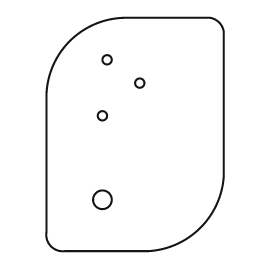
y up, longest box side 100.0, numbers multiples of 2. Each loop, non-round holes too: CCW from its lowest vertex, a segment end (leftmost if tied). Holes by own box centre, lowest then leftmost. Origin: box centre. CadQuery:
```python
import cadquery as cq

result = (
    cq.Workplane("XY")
    .moveTo(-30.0, -50.0)
    .lineTo(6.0, -50.0)
    .threePointArc((28.0, -40.0), (38.0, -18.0))
    .lineTo(38.0, 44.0)
    .threePointArc((36.0, 48.0), (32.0, 50.0))
    .lineTo(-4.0, 50.0)
    .threePointArc((-28.0, 40.0), (-38.0, 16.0))
    .lineTo(-38.0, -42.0)
    .threePointArc((-36.0, -48.0), (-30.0, -50.0))
    .close()
    .moveTo(-14.0, -28.0)
    .circle(4.0)
    .moveTo(-14.0, 8.0)
    .circle(2.0)
    .moveTo(2.0, 22.0)
    .circle(2.0)
    .moveTo(-12.0, 32.0)
    .circle(2.0)
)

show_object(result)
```